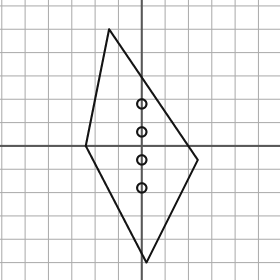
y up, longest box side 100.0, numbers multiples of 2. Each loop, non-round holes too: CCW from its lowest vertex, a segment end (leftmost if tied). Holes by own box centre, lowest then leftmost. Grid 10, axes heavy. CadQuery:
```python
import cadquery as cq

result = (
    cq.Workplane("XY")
    .moveTo(2.0, -50.0)
    .lineTo(24.0, -6.0)
    .lineTo(-14.0, 50.0)
    .lineTo(-24.0, 0.0)
    .close()
    .moveTo(0.0, -18.0)
    .circle(2.0)
    .moveTo(0.0, -6.0)
    .circle(2.0)
    .moveTo(0.0, 6.0)
    .circle(2.0)
    .moveTo(0.0, 18.0)
    .circle(2.0)
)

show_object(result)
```